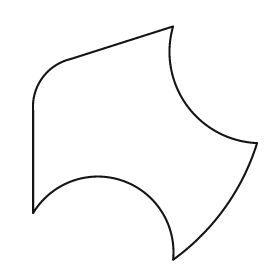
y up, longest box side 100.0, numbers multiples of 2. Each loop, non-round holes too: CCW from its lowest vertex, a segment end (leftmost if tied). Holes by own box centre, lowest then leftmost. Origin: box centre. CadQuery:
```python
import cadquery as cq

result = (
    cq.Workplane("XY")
    .moveTo(12.0, -50.0)
    .threePointArc((34.0, -28.0), (48.0, 0.0))
    .threePointArc((18.0, 16.0), (12.0, 50.0))
    .lineTo(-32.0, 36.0)
    .threePointArc((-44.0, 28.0), (-48.0, 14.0))
    .lineTo(-48.0, -30.0)
    .threePointArc((-10.0, -16.0), (12.0, -50.0))
    .close()
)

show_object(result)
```